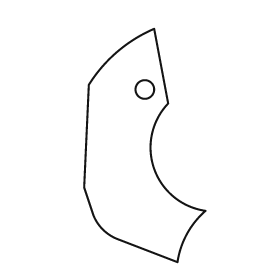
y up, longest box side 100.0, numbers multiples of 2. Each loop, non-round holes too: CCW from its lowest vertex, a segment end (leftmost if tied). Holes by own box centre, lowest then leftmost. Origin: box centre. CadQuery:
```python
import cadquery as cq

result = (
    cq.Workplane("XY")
    .moveTo(14.0, -50.0)
    .threePointArc((18.0, -38.0), (26.0, -28.0))
    .threePointArc((4.0, -10.0), (10.0, 18.0))
    .lineTo(4.0, 50.0)
    .threePointArc((-12.0, 40.0), (-24.0, 26.0))
    .lineTo(-26.0, -18.0)
    .lineTo(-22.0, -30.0)
    .threePointArc((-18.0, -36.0), (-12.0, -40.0))
    .close()
    .moveTo(0.0, 24.0)
    .circle(4.0)
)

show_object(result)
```